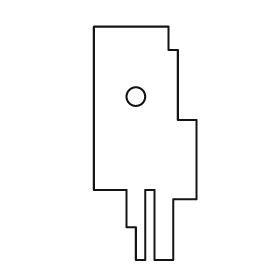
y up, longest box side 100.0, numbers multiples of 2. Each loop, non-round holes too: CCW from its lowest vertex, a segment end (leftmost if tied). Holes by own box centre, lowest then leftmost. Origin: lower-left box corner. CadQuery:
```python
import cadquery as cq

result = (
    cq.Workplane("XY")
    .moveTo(18.0, 0.0)
    .lineTo(22.0, 0.0)
    .lineTo(22.0, 30.0)
    .lineTo(26.0, 30.0)
    .lineTo(26.0, 0.0)
    .lineTo(34.0, 0.0)
    .lineTo(34.0, 26.0)
    .lineTo(44.0, 26.0)
    .lineTo(44.0, 60.0)
    .lineTo(36.0, 60.0)
    .lineTo(36.0, 90.0)
    .lineTo(32.0, 90.0)
    .lineTo(32.0, 100.0)
    .lineTo(0.0, 100.0)
    .lineTo(0.0, 30.0)
    .lineTo(14.0, 30.0)
    .lineTo(14.0, 14.0)
    .lineTo(18.0, 14.0)
    .close()
    .moveTo(18.0, 70.0)
    .circle(4.0)
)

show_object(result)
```